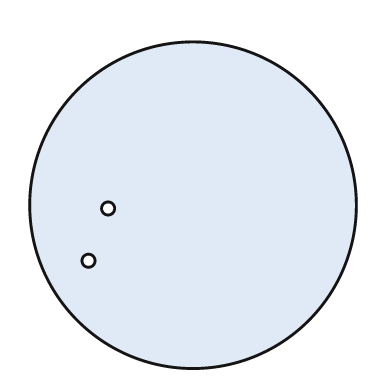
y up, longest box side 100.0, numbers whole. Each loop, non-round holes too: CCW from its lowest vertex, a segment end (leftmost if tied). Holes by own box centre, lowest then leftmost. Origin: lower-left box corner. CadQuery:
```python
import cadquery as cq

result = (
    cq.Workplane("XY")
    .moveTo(50.0, 50.0)
    .circle(50.0)
    .moveTo(18.0, 33.0)
    .circle(2.0)
    .moveTo(24.0, 49.0)
    .circle(2.0)
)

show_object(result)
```